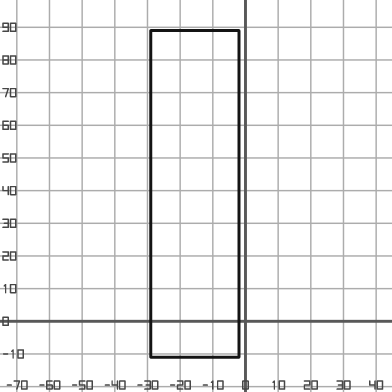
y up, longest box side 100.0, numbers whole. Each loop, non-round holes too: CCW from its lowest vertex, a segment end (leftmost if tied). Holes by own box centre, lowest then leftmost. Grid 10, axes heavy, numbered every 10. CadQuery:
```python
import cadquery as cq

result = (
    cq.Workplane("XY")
    .moveTo(-29.0, -11.0)
    .lineTo(-2.0, -11.0)
    .lineTo(-2.0, 89.0)
    .lineTo(-29.0, 89.0)
    .close()
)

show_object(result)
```